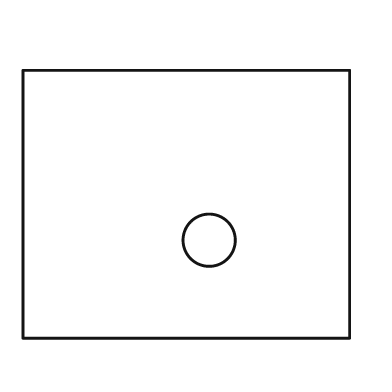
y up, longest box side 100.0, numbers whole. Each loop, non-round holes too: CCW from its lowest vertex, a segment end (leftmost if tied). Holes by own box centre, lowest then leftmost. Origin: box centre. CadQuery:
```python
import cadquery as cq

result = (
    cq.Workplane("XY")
    .moveTo(-50.0, -41.0)
    .lineTo(50.0, -41.0)
    .lineTo(50.0, 41.0)
    .lineTo(-50.0, 41.0)
    .close()
    .moveTo(7.0, -11.0)
    .circle(8.0)
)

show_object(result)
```